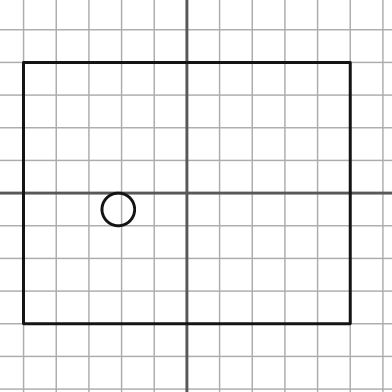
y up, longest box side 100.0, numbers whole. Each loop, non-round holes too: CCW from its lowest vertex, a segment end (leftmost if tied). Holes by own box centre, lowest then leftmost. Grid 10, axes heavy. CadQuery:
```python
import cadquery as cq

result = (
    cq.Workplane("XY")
    .moveTo(-50.0, -40.0)
    .lineTo(50.0, -40.0)
    .lineTo(50.0, 40.0)
    .lineTo(-50.0, 40.0)
    .close()
    .moveTo(-21.0, -5.0)
    .circle(5.0)
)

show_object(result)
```